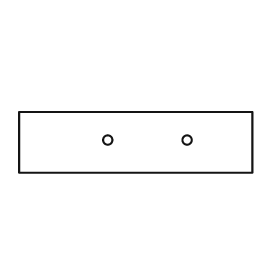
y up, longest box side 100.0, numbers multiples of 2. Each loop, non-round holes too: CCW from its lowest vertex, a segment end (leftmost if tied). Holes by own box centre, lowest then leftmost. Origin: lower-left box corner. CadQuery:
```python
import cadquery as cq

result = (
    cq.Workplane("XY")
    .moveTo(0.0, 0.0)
    .lineTo(100.0, 0.0)
    .lineTo(100.0, 26.0)
    .lineTo(0.0, 26.0)
    .close()
    .moveTo(38.0, 14.0)
    .circle(2.0)
    .moveTo(72.0, 14.0)
    .circle(2.0)
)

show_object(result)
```